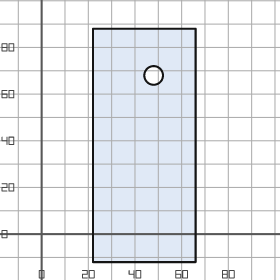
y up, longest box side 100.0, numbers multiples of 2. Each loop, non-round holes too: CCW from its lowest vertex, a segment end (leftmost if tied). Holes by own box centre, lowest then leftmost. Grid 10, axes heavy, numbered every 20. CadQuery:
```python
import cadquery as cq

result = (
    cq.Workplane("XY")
    .moveTo(22.0, -12.0)
    .lineTo(66.0, -12.0)
    .lineTo(66.0, 88.0)
    .lineTo(22.0, 88.0)
    .close()
    .moveTo(48.0, 68.0)
    .circle(4.0)
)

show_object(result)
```